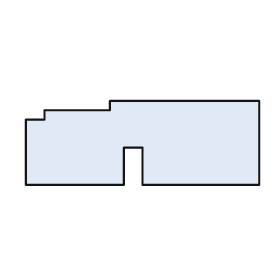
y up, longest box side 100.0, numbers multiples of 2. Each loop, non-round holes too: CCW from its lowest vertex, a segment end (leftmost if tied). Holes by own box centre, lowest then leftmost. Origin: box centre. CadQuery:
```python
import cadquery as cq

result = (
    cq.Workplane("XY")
    .moveTo(-50.0, -18.0)
    .lineTo(-8.0, -18.0)
    .lineTo(-8.0, -2.0)
    .lineTo(0.0, -2.0)
    .lineTo(0.0, -18.0)
    .lineTo(50.0, -18.0)
    .lineTo(50.0, 18.0)
    .lineTo(-14.0, 18.0)
    .lineTo(-14.0, 14.0)
    .lineTo(-42.0, 14.0)
    .lineTo(-42.0, 10.0)
    .lineTo(-50.0, 10.0)
    .close()
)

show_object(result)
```